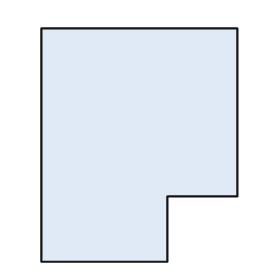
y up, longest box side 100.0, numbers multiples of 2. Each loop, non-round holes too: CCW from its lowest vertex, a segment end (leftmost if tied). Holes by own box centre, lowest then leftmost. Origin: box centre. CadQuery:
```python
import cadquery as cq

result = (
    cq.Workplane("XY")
    .moveTo(-42.0, -50.0)
    .lineTo(12.0, -50.0)
    .lineTo(12.0, -22.0)
    .lineTo(42.0, -22.0)
    .lineTo(42.0, 50.0)
    .lineTo(-42.0, 50.0)
    .close()
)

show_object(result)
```